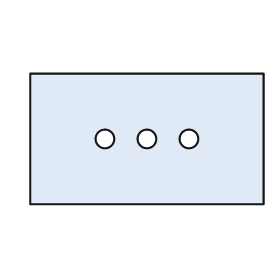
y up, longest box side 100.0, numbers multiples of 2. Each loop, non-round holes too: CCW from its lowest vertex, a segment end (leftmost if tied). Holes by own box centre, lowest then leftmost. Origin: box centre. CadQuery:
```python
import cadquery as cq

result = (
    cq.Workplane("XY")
    .moveTo(-50.0, -28.0)
    .lineTo(50.0, -28.0)
    .lineTo(50.0, 28.0)
    .lineTo(-50.0, 28.0)
    .close()
    .moveTo(-18.0, 0.0)
    .circle(4.0)
    .moveTo(0.0, 0.0)
    .circle(4.0)
    .moveTo(18.0, 0.0)
    .circle(4.0)
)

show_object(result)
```